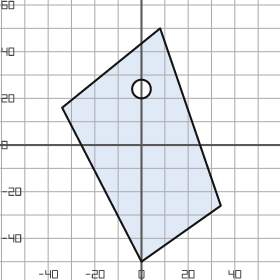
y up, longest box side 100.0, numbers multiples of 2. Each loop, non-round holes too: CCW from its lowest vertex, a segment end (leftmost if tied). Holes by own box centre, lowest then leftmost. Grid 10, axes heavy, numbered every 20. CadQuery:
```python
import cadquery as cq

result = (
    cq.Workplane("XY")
    .moveTo(0.0, -50.0)
    .lineTo(34.0, -26.0)
    .lineTo(8.0, 50.0)
    .lineTo(-34.0, 16.0)
    .close()
    .moveTo(0.0, 24.0)
    .circle(4.0)
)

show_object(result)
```